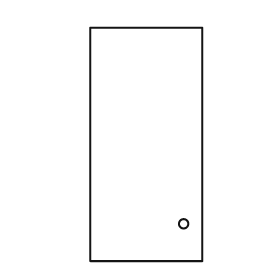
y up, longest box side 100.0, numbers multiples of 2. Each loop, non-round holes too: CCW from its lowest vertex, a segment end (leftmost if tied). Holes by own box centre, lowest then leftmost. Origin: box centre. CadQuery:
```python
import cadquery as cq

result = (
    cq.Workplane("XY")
    .moveTo(-24.0, -50.0)
    .lineTo(24.0, -50.0)
    .lineTo(24.0, 50.0)
    .lineTo(-24.0, 50.0)
    .close()
    .moveTo(16.0, -34.0)
    .circle(2.0)
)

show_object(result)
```